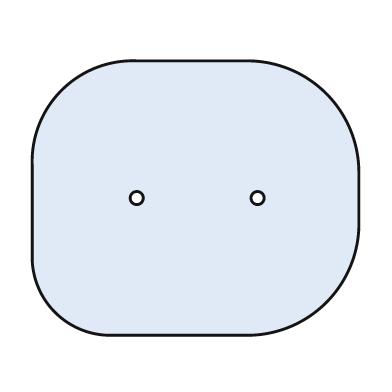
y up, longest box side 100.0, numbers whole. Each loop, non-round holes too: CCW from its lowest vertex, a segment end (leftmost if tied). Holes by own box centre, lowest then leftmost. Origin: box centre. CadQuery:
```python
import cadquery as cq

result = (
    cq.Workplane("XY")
    .moveTo(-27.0, -42.0)
    .lineTo(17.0, -42.0)
    .threePointArc((40.0, -32.0), (50.0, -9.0))
    .lineTo(50.0, 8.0)
    .threePointArc((40.0, 32.0), (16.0, 42.0))
    .lineTo(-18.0, 42.0)
    .threePointArc((-41.0, 33.0), (-50.0, 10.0))
    .lineTo(-50.0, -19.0)
    .threePointArc((-43.0, -35.0), (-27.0, -42.0))
    .close()
    .moveTo(-18.0, 0.0)
    .circle(2.0)
    .moveTo(19.0, 0.0)
    .circle(2.0)
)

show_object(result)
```